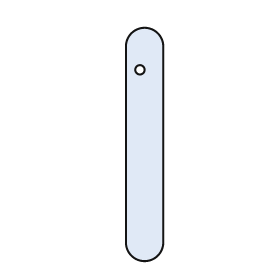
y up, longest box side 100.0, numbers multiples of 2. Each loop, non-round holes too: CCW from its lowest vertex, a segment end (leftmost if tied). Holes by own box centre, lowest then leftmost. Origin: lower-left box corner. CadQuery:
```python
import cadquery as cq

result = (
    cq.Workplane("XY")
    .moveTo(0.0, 8.0)
    .threePointArc((8.0, 0.0), (16.0, 8.0))
    .lineTo(16.0, 92.0)
    .threePointArc((8.0, 100.0), (0.0, 92.0))
    .close()
    .moveTo(6.0, 82.0)
    .circle(2.0)
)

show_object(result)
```